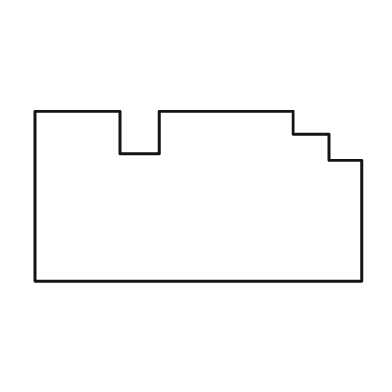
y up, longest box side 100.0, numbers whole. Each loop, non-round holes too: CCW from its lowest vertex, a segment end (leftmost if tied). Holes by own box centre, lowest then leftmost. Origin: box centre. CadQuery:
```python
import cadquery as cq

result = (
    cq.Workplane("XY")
    .moveTo(-50.0, -26.0)
    .lineTo(50.0, -26.0)
    .lineTo(50.0, 11.0)
    .lineTo(40.0, 11.0)
    .lineTo(40.0, 19.0)
    .lineTo(29.0, 19.0)
    .lineTo(29.0, 26.0)
    .lineTo(-12.0, 26.0)
    .lineTo(-12.0, 13.0)
    .lineTo(-24.0, 13.0)
    .lineTo(-24.0, 26.0)
    .lineTo(-50.0, 26.0)
    .close()
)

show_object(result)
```